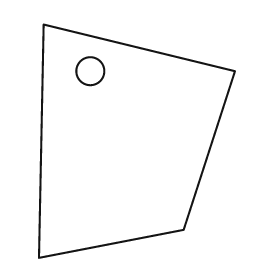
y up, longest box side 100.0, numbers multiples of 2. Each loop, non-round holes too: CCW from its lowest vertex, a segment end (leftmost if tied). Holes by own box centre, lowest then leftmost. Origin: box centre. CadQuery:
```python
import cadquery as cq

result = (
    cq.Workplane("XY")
    .moveTo(-42.0, -50.0)
    .lineTo(20.0, -38.0)
    .lineTo(42.0, 30.0)
    .lineTo(-40.0, 50.0)
    .close()
    .moveTo(-20.0, 30.0)
    .circle(6.0)
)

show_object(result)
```